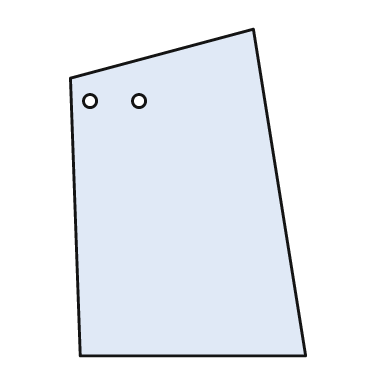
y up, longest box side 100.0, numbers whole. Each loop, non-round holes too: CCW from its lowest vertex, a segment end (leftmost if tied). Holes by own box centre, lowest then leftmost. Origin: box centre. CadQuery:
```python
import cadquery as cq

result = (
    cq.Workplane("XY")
    .moveTo(-33.0, -50.0)
    .lineTo(36.0, -50.0)
    .lineTo(20.0, 50.0)
    .lineTo(-36.0, 35.0)
    .close()
    .moveTo(-30.0, 28.0)
    .circle(2.0)
    .moveTo(-15.0, 28.0)
    .circle(2.0)
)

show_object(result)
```